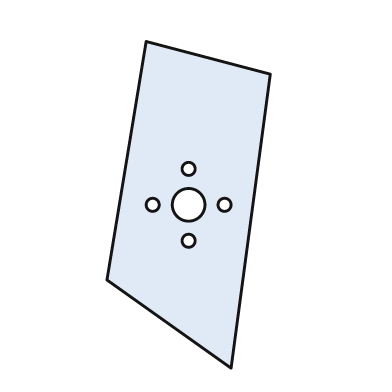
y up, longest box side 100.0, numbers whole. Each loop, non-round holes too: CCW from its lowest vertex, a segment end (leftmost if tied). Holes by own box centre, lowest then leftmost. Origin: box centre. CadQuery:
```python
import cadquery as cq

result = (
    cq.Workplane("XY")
    .moveTo(13.0, -50.0)
    .lineTo(25.0, 40.0)
    .lineTo(-13.0, 50.0)
    .lineTo(-25.0, -23.0)
    .close()
    .moveTo(0.0, -11.0)
    .circle(2.0)
    .moveTo(-11.0, 0.0)
    .circle(2.0)
    .moveTo(0.0, 0.0)
    .circle(5.0)
    .moveTo(11.0, 0.0)
    .circle(2.0)
    .moveTo(0.0, 11.0)
    .circle(2.0)
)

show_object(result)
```